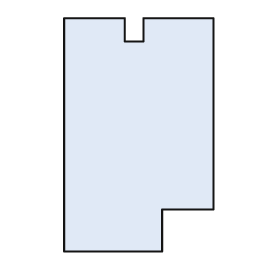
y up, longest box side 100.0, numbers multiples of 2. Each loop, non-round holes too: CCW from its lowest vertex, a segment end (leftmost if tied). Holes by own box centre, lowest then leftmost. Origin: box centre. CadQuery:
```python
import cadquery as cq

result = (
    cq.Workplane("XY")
    .moveTo(-32.0, -50.0)
    .lineTo(10.0, -50.0)
    .lineTo(10.0, -32.0)
    .lineTo(32.0, -32.0)
    .lineTo(32.0, 50.0)
    .lineTo(2.0, 50.0)
    .lineTo(2.0, 40.0)
    .lineTo(-6.0, 40.0)
    .lineTo(-6.0, 50.0)
    .lineTo(-32.0, 50.0)
    .close()
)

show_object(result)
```